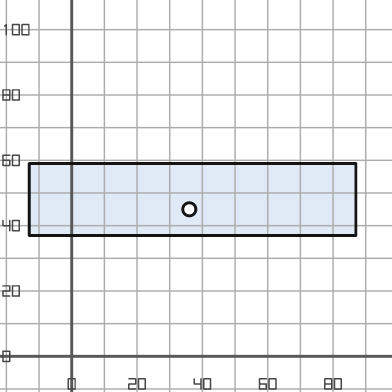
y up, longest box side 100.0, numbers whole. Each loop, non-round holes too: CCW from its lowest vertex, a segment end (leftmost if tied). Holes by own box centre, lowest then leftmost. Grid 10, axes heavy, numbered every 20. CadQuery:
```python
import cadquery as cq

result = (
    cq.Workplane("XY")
    .moveTo(-13.0, 37.0)
    .lineTo(87.0, 37.0)
    .lineTo(87.0, 59.0)
    .lineTo(-13.0, 59.0)
    .close()
    .moveTo(36.0, 45.0)
    .circle(2.0)
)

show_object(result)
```